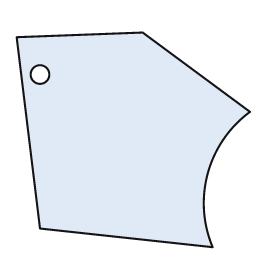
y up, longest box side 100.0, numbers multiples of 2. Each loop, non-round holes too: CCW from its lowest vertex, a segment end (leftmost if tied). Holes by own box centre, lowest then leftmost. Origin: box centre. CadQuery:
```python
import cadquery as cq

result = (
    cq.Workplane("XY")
    .moveTo(34.0, -46.0)
    .threePointArc((32.0, -14.0), (50.0, 12.0))
    .lineTo(4.0, 46.0)
    .lineTo(-50.0, 44.0)
    .lineTo(-40.0, -38.0)
    .close()
    .moveTo(-40.0, 28.0)
    .circle(4.0)
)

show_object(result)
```